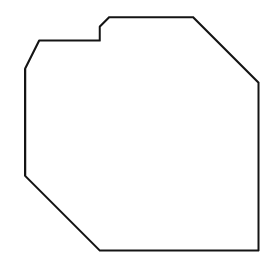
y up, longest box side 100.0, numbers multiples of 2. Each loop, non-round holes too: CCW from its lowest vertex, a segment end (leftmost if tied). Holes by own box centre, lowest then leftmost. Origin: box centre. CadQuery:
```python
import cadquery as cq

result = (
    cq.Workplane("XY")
    .moveTo(-18.0, -50.0)
    .lineTo(50.0, -50.0)
    .lineTo(50.0, 22.0)
    .lineTo(22.0, 50.0)
    .lineTo(-14.0, 50.0)
    .lineTo(-18.0, 46.0)
    .lineTo(-18.0, 40.0)
    .lineTo(-44.0, 40.0)
    .lineTo(-50.0, 28.0)
    .lineTo(-50.0, -18.0)
    .close()
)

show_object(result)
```